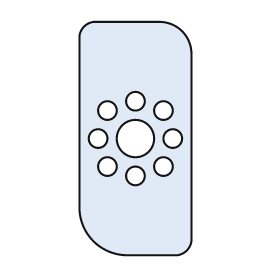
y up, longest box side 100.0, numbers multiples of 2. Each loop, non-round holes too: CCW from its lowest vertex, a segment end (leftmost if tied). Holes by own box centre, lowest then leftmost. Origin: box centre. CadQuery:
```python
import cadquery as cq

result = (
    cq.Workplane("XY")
    .moveTo(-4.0, -50.0)
    .lineTo(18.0, -50.0)
    .threePointArc((22.0, -48.0), (24.0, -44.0))
    .lineTo(24.0, 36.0)
    .threePointArc((20.0, 46.0), (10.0, 50.0))
    .lineTo(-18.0, 50.0)
    .threePointArc((-22.0, 48.0), (-24.0, 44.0))
    .lineTo(-24.0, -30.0)
    .threePointArc((-18.0, -44.0), (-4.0, -50.0))
    .close()
    .moveTo(0.0, -16.0)
    .circle(4.0)
    .moveTo(-12.0, -12.0)
    .circle(4.0)
    .moveTo(12.0, -12.0)
    .circle(4.0)
    .moveTo(-16.0, 0.0)
    .circle(4.0)
    .moveTo(0.0, 0.0)
    .circle(8.0)
    .moveTo(16.0, 0.0)
    .circle(4.0)
    .moveTo(-12.0, 12.0)
    .circle(4.0)
    .moveTo(12.0, 12.0)
    .circle(4.0)
    .moveTo(0.0, 16.0)
    .circle(4.0)
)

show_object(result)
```